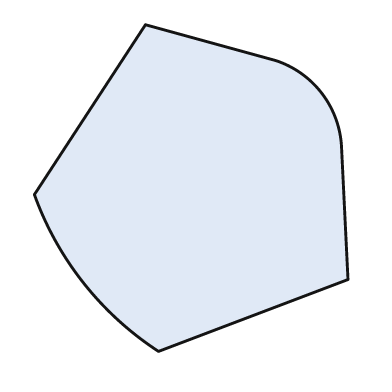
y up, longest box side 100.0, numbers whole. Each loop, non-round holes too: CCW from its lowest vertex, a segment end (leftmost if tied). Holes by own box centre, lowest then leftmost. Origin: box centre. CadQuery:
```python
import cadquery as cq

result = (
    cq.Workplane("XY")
    .moveTo(-10.0, -50.0)
    .lineTo(48.0, -28.0)
    .lineTo(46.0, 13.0)
    .threePointArc((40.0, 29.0), (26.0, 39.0))
    .lineTo(-14.0, 50.0)
    .lineTo(-48.0, -2.0)
    .threePointArc((-33.0, -29.0), (-10.0, -50.0))
    .close()
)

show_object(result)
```